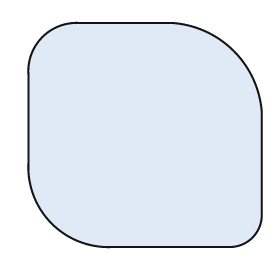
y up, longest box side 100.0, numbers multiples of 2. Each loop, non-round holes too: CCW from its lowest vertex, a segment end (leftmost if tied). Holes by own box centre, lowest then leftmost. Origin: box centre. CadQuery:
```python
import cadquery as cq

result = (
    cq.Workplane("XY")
    .moveTo(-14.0, -48.0)
    .lineTo(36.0, -48.0)
    .threePointArc((46.0, -44.0), (50.0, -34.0))
    .lineTo(50.0, 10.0)
    .threePointArc((38.0, 36.0), (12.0, 48.0))
    .lineTo(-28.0, 48.0)
    .threePointArc((-44.0, 42.0), (-50.0, 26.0))
    .lineTo(-50.0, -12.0)
    .threePointArc((-40.0, -38.0), (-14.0, -48.0))
    .close()
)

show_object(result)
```